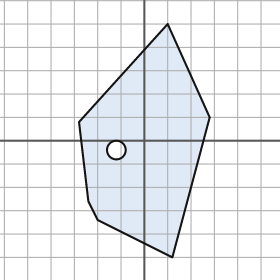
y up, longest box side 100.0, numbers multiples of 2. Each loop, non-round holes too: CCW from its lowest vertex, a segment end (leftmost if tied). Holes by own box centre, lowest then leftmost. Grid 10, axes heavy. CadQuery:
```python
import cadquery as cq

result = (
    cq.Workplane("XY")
    .moveTo(12.0, -50.0)
    .lineTo(28.0, 10.0)
    .lineTo(10.0, 50.0)
    .lineTo(-28.0, 8.0)
    .lineTo(-24.0, -26.0)
    .lineTo(-20.0, -34.0)
    .close()
    .moveTo(-12.0, -4.0)
    .circle(4.0)
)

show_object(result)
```